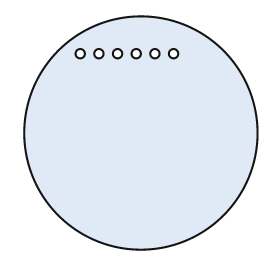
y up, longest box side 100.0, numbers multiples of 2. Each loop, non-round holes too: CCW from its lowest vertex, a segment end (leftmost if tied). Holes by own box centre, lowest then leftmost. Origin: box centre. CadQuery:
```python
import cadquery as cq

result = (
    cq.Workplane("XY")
    .moveTo(0.0, 0.0)
    .circle(50.0)
    .moveTo(-26.0, 34.0)
    .circle(2.0)
    .moveTo(-18.0, 34.0)
    .circle(2.0)
    .moveTo(-10.0, 34.0)
    .circle(2.0)
    .moveTo(-2.0, 34.0)
    .circle(2.0)
    .moveTo(6.0, 34.0)
    .circle(2.0)
    .moveTo(14.0, 34.0)
    .circle(2.0)
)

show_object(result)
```